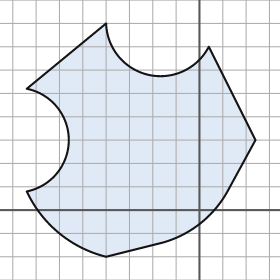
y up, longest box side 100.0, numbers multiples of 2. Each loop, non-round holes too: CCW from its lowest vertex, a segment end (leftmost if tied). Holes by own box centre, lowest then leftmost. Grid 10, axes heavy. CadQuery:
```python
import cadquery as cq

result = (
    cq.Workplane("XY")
    .moveTo(-40.0, -20.0)
    .lineTo(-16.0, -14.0)
    .threePointArc((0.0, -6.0), (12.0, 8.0))
    .lineTo(24.0, 30.0)
    .lineTo(4.0, 70.0)
    .threePointArc((-22.0, 58.0), (-40.0, 80.0))
    .lineTo(-74.0, 52.0)
    .threePointArc((-56.0, 30.0), (-74.0, 8.0))
    .threePointArc((-60.0, -10.0), (-40.0, -20.0))
    .close()
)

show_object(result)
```